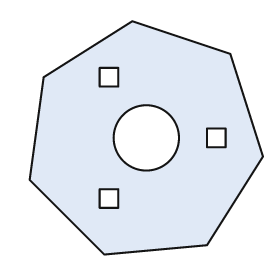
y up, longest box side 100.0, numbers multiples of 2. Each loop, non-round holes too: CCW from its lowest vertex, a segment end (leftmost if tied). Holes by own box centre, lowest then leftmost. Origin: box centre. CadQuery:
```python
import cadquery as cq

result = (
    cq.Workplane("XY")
    .moveTo(-18.0, -50.0)
    .lineTo(26.0, -46.0)
    .lineTo(50.0, -8.0)
    .lineTo(36.0, 36.0)
    .lineTo(-6.0, 50.0)
    .lineTo(-44.0, 26.0)
    .lineTo(-50.0, -18.0)
    .close()
    .moveTo(-20.0, -30.0)
    .lineTo(-12.0, -30.0)
    .lineTo(-12.0, -22.0)
    .lineTo(-20.0, -22.0)
    .close()
    .moveTo(0.0, 0.0)
    .circle(14.0)
    .moveTo(26.0, -4.0)
    .lineTo(34.0, -4.0)
    .lineTo(34.0, 4.0)
    .lineTo(26.0, 4.0)
    .close()
    .moveTo(-20.0, 22.0)
    .lineTo(-12.0, 22.0)
    .lineTo(-12.0, 30.0)
    .lineTo(-20.0, 30.0)
    .close()
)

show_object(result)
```